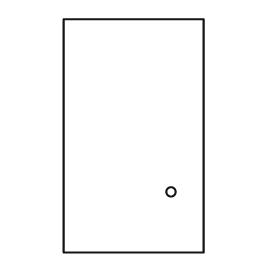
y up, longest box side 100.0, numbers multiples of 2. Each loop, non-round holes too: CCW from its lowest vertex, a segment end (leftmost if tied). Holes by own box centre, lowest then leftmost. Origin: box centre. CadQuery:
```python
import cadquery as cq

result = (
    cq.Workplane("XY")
    .moveTo(-30.0, -50.0)
    .lineTo(30.0, -50.0)
    .lineTo(30.0, 50.0)
    .lineTo(-30.0, 50.0)
    .close()
    .moveTo(16.0, -24.0)
    .circle(2.0)
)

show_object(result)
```